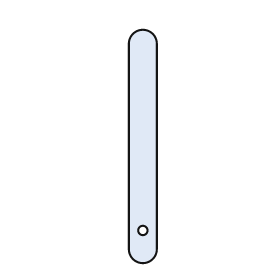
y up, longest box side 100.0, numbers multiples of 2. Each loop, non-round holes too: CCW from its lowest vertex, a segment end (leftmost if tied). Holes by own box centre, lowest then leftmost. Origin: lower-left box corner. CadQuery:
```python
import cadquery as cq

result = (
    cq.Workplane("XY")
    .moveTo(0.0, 6.0)
    .threePointArc((6.0, 0.0), (12.0, 6.0))
    .lineTo(12.0, 94.0)
    .threePointArc((6.0, 100.0), (0.0, 94.0))
    .close()
    .moveTo(6.0, 14.0)
    .circle(2.0)
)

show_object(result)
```